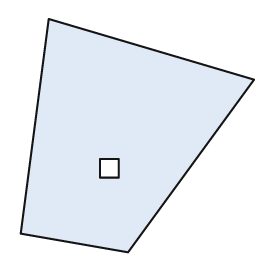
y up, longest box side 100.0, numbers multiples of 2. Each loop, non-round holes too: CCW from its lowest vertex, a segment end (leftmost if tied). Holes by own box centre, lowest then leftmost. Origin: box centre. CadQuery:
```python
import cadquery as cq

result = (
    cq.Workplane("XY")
    .moveTo(-4.0, -50.0)
    .lineTo(50.0, 24.0)
    .lineTo(-38.0, 50.0)
    .lineTo(-50.0, -42.0)
    .close()
    .moveTo(-16.0, -18.0)
    .lineTo(-8.0, -18.0)
    .lineTo(-8.0, -10.0)
    .lineTo(-16.0, -10.0)
    .close()
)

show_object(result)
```